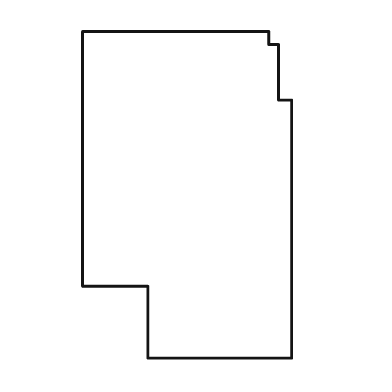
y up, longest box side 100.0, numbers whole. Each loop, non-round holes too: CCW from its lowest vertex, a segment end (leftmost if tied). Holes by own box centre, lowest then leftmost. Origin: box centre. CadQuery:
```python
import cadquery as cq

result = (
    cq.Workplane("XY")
    .moveTo(-12.0, -50.0)
    .lineTo(32.0, -50.0)
    .lineTo(32.0, 29.0)
    .lineTo(28.0, 29.0)
    .lineTo(28.0, 46.0)
    .lineTo(25.0, 46.0)
    .lineTo(25.0, 50.0)
    .lineTo(-32.0, 50.0)
    .lineTo(-32.0, -28.0)
    .lineTo(-12.0, -28.0)
    .close()
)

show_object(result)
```